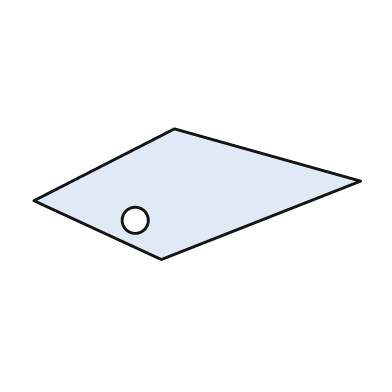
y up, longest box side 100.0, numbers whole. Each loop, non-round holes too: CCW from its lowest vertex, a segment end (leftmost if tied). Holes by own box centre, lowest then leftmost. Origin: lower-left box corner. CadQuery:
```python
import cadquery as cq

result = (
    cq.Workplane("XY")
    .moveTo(39.0, 0.0)
    .lineTo(100.0, 24.0)
    .lineTo(43.0, 40.0)
    .lineTo(0.0, 18.0)
    .close()
    .moveTo(31.0, 12.0)
    .circle(4.0)
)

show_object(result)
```